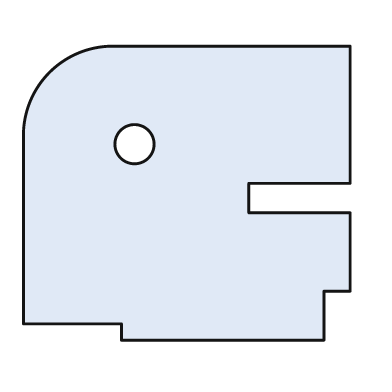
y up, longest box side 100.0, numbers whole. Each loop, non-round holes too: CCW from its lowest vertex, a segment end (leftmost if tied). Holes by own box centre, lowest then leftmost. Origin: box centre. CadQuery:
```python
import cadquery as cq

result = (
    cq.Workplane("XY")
    .moveTo(-20.0, -45.0)
    .lineTo(42.0, -45.0)
    .lineTo(42.0, -30.0)
    .lineTo(50.0, -30.0)
    .lineTo(50.0, -6.0)
    .lineTo(19.0, -6.0)
    .lineTo(19.0, 3.0)
    .lineTo(50.0, 3.0)
    .lineTo(50.0, 45.0)
    .lineTo(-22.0, 45.0)
    .threePointArc((-42.0, 37.0), (-50.0, 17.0))
    .lineTo(-50.0, -40.0)
    .lineTo(-20.0, -40.0)
    .close()
    .moveTo(-16.0, 15.0)
    .circle(6.0)
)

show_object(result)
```